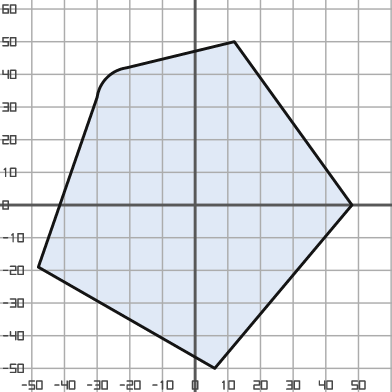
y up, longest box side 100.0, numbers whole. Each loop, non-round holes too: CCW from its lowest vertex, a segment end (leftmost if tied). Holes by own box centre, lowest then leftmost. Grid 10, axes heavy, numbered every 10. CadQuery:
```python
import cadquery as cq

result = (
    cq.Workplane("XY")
    .moveTo(6.0, -50.0)
    .lineTo(48.0, 0.0)
    .lineTo(12.0, 50.0)
    .lineTo(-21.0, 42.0)
    .threePointArc((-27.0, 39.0), (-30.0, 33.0))
    .lineTo(-48.0, -19.0)
    .close()
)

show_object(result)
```